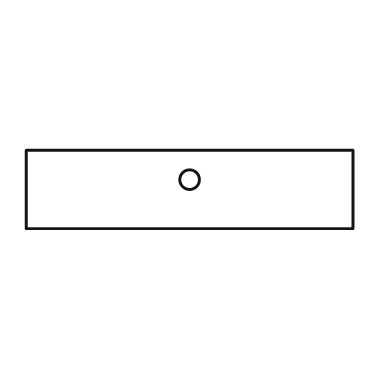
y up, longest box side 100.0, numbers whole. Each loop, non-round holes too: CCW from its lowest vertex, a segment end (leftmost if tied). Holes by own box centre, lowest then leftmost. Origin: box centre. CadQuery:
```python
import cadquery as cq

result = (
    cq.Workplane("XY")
    .moveTo(-50.0, -12.0)
    .lineTo(50.0, -12.0)
    .lineTo(50.0, 12.0)
    .lineTo(-50.0, 12.0)
    .close()
    .moveTo(0.0, 3.0)
    .circle(3.0)
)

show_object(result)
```